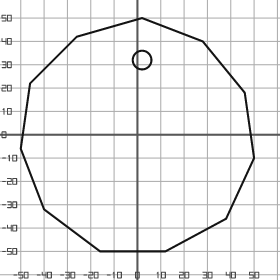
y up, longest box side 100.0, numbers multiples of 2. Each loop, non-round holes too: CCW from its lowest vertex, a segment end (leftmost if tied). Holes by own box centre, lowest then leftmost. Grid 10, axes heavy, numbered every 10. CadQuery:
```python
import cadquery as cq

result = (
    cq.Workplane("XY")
    .moveTo(-16.0, -50.0)
    .lineTo(12.0, -50.0)
    .lineTo(38.0, -36.0)
    .lineTo(50.0, -10.0)
    .lineTo(46.0, 18.0)
    .lineTo(28.0, 40.0)
    .lineTo(2.0, 50.0)
    .lineTo(-26.0, 42.0)
    .lineTo(-46.0, 22.0)
    .lineTo(-50.0, -6.0)
    .lineTo(-40.0, -32.0)
    .close()
    .moveTo(2.0, 32.0)
    .circle(4.0)
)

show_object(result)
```